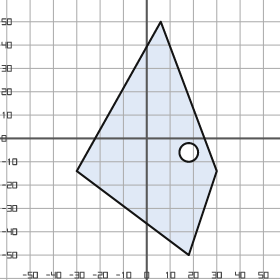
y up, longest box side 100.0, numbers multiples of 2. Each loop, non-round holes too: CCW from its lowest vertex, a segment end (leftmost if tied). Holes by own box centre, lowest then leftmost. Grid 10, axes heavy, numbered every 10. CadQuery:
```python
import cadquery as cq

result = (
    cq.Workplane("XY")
    .moveTo(18.0, -50.0)
    .lineTo(30.0, -14.0)
    .lineTo(6.0, 50.0)
    .lineTo(-30.0, -14.0)
    .close()
    .moveTo(18.0, -6.0)
    .circle(4.0)
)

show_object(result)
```